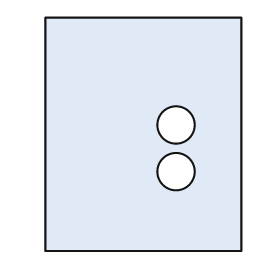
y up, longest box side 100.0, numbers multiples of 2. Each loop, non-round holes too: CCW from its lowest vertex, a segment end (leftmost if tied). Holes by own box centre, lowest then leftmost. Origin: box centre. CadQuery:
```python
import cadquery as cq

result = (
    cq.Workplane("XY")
    .moveTo(-42.0, -50.0)
    .lineTo(42.0, -50.0)
    .lineTo(42.0, 50.0)
    .lineTo(-42.0, 50.0)
    .close()
    .moveTo(14.0, -16.0)
    .circle(8.0)
    .moveTo(14.0, 4.0)
    .circle(8.0)
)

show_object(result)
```